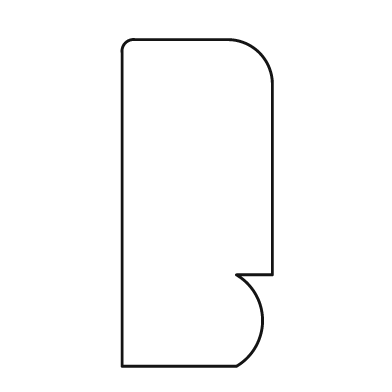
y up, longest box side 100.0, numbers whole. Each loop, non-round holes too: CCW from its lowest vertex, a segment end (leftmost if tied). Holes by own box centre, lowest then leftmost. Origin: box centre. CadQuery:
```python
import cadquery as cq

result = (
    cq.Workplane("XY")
    .moveTo(-23.0, -50.0)
    .lineTo(12.0, -50.0)
    .threePointArc((20.0, -36.0), (12.0, -22.0))
    .lineTo(23.0, -22.0)
    .lineTo(23.0, 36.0)
    .threePointArc((19.0, 46.0), (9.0, 50.0))
    .lineTo(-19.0, 50.0)
    .threePointArc((-22.0, 49.0), (-23.0, 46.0))
    .close()
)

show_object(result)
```